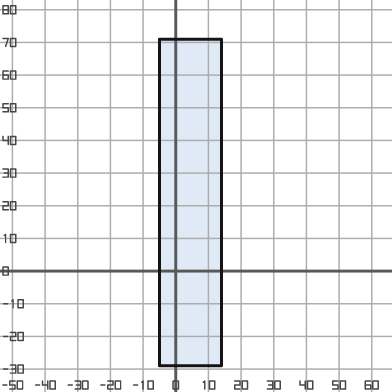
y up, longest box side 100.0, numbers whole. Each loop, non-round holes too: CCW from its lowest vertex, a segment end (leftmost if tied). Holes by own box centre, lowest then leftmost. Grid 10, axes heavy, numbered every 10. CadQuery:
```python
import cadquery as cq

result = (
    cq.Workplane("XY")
    .moveTo(-5.0, -29.0)
    .lineTo(14.0, -29.0)
    .lineTo(14.0, 71.0)
    .lineTo(-5.0, 71.0)
    .close()
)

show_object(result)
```